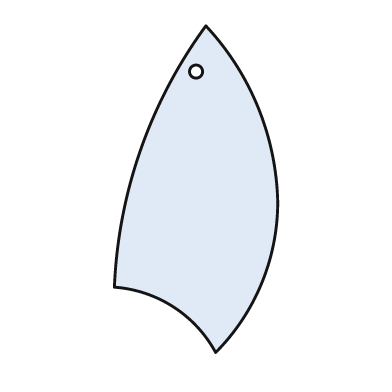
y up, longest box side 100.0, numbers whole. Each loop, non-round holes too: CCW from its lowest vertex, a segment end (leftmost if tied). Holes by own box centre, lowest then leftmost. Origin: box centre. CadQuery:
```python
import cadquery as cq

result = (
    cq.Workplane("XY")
    .moveTo(6.0, -50.0)
    .threePointArc((20.0, -29.0), (25.0, -4.0))
    .threePointArc((19.0, 25.0), (3.0, 50.0))
    .threePointArc((-17.0, 12.0), (-25.0, -30.0))
    .threePointArc((-7.0, -36.0), (6.0, -50.0))
    .close()
    .moveTo(0.0, 36.0)
    .circle(2.0)
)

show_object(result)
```